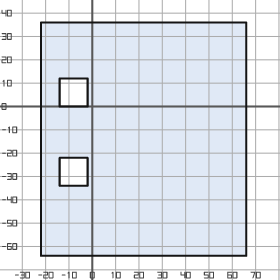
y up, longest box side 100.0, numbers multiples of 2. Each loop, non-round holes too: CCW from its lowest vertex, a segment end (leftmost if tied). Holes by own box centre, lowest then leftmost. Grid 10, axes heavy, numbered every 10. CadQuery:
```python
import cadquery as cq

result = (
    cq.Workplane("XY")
    .moveTo(-22.0, -64.0)
    .lineTo(66.0, -64.0)
    .lineTo(66.0, 36.0)
    .lineTo(-22.0, 36.0)
    .close()
    .moveTo(-14.0, -34.0)
    .lineTo(-2.0, -34.0)
    .lineTo(-2.0, -22.0)
    .lineTo(-14.0, -22.0)
    .close()
    .moveTo(-14.0, 0.0)
    .lineTo(-2.0, 0.0)
    .lineTo(-2.0, 12.0)
    .lineTo(-14.0, 12.0)
    .close()
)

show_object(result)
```